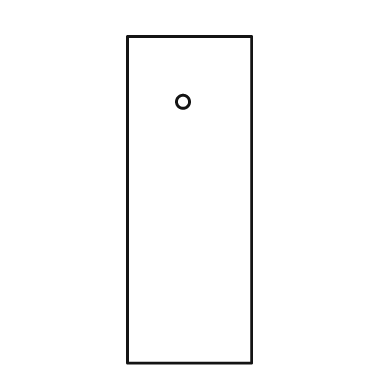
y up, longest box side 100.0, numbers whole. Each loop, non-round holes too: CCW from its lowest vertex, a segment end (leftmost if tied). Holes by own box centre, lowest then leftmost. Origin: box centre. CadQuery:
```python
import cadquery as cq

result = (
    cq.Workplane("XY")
    .moveTo(-19.0, -50.0)
    .lineTo(19.0, -50.0)
    .lineTo(19.0, 50.0)
    .lineTo(-19.0, 50.0)
    .close()
    .moveTo(-2.0, 30.0)
    .circle(2.0)
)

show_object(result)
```